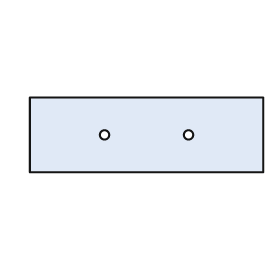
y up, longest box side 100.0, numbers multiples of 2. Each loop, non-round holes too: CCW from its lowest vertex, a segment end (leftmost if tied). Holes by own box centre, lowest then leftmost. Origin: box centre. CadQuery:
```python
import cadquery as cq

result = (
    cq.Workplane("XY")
    .moveTo(-50.0, -16.0)
    .lineTo(50.0, -16.0)
    .lineTo(50.0, 16.0)
    .lineTo(-50.0, 16.0)
    .close()
    .moveTo(-18.0, 0.0)
    .circle(2.0)
    .moveTo(18.0, 0.0)
    .circle(2.0)
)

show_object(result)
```